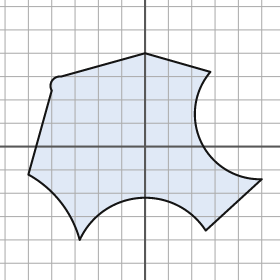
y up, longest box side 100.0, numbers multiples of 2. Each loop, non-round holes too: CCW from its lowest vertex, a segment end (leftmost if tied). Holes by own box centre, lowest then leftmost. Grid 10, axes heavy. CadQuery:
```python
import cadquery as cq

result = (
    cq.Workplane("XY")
    .moveTo(-28.0, -40.0)
    .threePointArc((-2.0, -22.0), (26.0, -36.0))
    .lineTo(50.0, -14.0)
    .threePointArc((24.0, 2.0), (28.0, 32.0))
    .lineTo(0.0, 40.0)
    .lineTo(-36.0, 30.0)
    .threePointArc((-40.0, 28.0), (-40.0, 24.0))
    .lineTo(-50.0, -12.0)
    .threePointArc((-36.0, -24.0), (-28.0, -40.0))
    .close()
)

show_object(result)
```